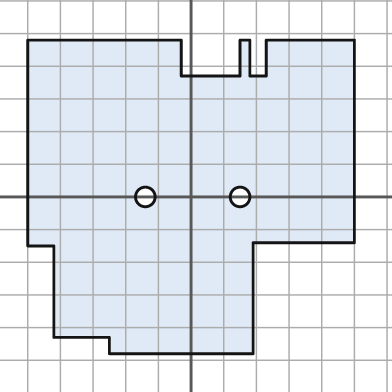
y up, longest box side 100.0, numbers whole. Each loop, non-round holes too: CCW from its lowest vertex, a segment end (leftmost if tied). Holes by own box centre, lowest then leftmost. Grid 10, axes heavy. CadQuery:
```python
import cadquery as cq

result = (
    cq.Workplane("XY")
    .moveTo(-25.0, -48.0)
    .lineTo(19.0, -48.0)
    .lineTo(19.0, -14.0)
    .lineTo(50.0, -14.0)
    .lineTo(50.0, 48.0)
    .lineTo(23.0, 48.0)
    .lineTo(23.0, 37.0)
    .lineTo(18.0, 37.0)
    .lineTo(18.0, 48.0)
    .lineTo(15.0, 48.0)
    .lineTo(15.0, 37.0)
    .lineTo(-3.0, 37.0)
    .lineTo(-3.0, 48.0)
    .lineTo(-50.0, 48.0)
    .lineTo(-50.0, -15.0)
    .lineTo(-42.0, -15.0)
    .lineTo(-42.0, -43.0)
    .lineTo(-25.0, -43.0)
    .close()
    .moveTo(-14.0, 0.0)
    .circle(3.0)
    .moveTo(15.0, 0.0)
    .circle(3.0)
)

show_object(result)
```